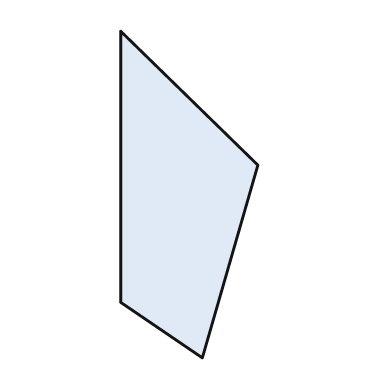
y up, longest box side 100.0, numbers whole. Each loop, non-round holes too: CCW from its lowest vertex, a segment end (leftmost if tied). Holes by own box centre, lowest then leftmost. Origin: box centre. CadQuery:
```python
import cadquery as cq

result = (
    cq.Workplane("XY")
    .moveTo(4.0, -50.0)
    .lineTo(21.0, 9.0)
    .lineTo(-21.0, 50.0)
    .lineTo(-21.0, -33.0)
    .close()
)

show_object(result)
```